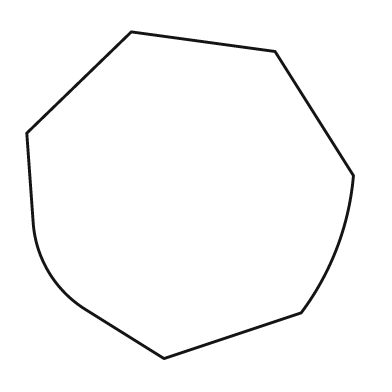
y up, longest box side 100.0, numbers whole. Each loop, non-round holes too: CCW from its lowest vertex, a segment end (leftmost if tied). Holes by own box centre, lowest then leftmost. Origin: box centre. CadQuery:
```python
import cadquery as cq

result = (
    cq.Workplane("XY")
    .moveTo(-8.0, -50.0)
    .lineTo(34.0, -36.0)
    .threePointArc((45.0, -16.0), (50.0, 6.0))
    .lineTo(26.0, 44.0)
    .lineTo(-18.0, 50.0)
    .lineTo(-50.0, 19.0)
    .lineTo(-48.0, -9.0)
    .threePointArc((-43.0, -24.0), (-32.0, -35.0))
    .close()
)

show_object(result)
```